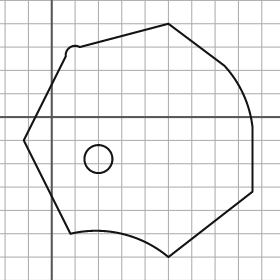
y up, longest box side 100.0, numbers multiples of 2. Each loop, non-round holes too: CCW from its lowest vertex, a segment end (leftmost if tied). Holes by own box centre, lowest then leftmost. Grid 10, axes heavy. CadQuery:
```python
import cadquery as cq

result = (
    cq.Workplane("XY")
    .moveTo(50.0, -60.0)
    .lineTo(86.0, -32.0)
    .lineTo(86.0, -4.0)
    .threePointArc((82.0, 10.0), (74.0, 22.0))
    .lineTo(50.0, 40.0)
    .lineTo(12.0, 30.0)
    .threePointArc((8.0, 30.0), (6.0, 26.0))
    .lineTo(-12.0, -10.0)
    .lineTo(8.0, -50.0)
    .threePointArc((30.0, -50.0), (50.0, -60.0))
    .close()
    .moveTo(20.0, -18.0)
    .circle(6.0)
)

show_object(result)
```